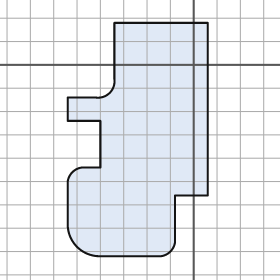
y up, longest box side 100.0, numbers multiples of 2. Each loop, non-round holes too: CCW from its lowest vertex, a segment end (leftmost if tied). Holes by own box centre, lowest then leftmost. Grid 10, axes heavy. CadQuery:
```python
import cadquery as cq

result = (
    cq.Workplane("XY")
    .moveTo(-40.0, -82.0)
    .lineTo(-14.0, -82.0)
    .threePointArc((-10.0, -80.0), (-8.0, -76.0))
    .lineTo(-8.0, -56.0)
    .lineTo(6.0, -56.0)
    .lineTo(6.0, 18.0)
    .lineTo(-34.0, 18.0)
    .lineTo(-34.0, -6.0)
    .threePointArc((-36.0, -12.0), (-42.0, -14.0))
    .lineTo(-54.0, -14.0)
    .lineTo(-54.0, -24.0)
    .lineTo(-40.0, -24.0)
    .lineTo(-40.0, -44.0)
    .lineTo(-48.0, -44.0)
    .threePointArc((-52.0, -46.0), (-54.0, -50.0))
    .lineTo(-54.0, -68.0)
    .threePointArc((-50.0, -78.0), (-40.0, -82.0))
    .close()
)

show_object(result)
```